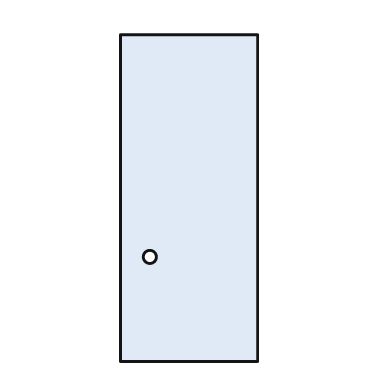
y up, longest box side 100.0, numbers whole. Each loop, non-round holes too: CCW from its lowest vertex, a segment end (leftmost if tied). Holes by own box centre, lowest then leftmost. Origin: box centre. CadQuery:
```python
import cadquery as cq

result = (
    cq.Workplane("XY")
    .moveTo(-21.0, -50.0)
    .lineTo(21.0, -50.0)
    .lineTo(21.0, 50.0)
    .lineTo(-21.0, 50.0)
    .close()
    .moveTo(-12.0, -18.0)
    .circle(2.0)
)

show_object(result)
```